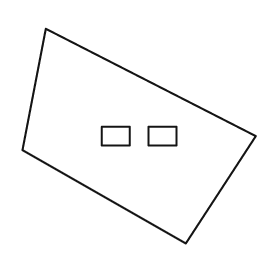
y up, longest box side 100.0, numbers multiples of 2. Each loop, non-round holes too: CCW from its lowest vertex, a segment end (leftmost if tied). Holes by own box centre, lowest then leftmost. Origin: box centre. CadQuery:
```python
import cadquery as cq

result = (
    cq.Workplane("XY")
    .moveTo(20.0, -46.0)
    .lineTo(50.0, 0.0)
    .lineTo(-40.0, 46.0)
    .lineTo(-50.0, -6.0)
    .close()
    .moveTo(-16.0, -4.0)
    .lineTo(-4.0, -4.0)
    .lineTo(-4.0, 4.0)
    .lineTo(-16.0, 4.0)
    .close()
    .moveTo(4.0, -4.0)
    .lineTo(16.0, -4.0)
    .lineTo(16.0, 4.0)
    .lineTo(4.0, 4.0)
    .close()
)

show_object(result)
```